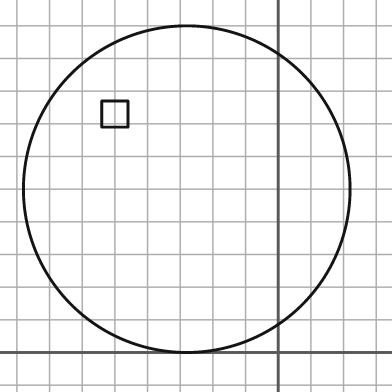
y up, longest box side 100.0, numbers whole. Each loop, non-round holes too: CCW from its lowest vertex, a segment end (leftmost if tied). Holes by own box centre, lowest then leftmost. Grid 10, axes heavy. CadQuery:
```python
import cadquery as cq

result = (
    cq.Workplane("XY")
    .moveTo(-28.0, 50.0)
    .circle(50.0)
    .moveTo(-54.0, 69.0)
    .lineTo(-46.0, 69.0)
    .lineTo(-46.0, 77.0)
    .lineTo(-54.0, 77.0)
    .close()
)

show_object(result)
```